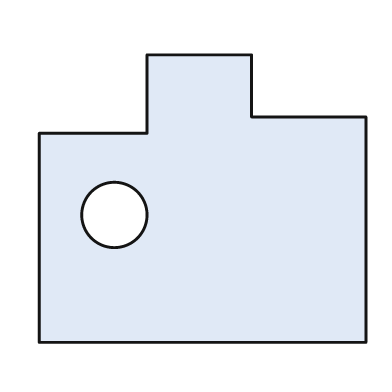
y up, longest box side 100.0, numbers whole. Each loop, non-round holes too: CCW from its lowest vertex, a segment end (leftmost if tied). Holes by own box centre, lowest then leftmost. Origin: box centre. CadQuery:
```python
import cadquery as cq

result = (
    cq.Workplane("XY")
    .moveTo(-50.0, -44.0)
    .lineTo(50.0, -44.0)
    .lineTo(50.0, 25.0)
    .lineTo(15.0, 25.0)
    .lineTo(15.0, 44.0)
    .lineTo(-17.0, 44.0)
    .lineTo(-17.0, 20.0)
    .lineTo(-50.0, 20.0)
    .close()
    .moveTo(-27.0, -5.0)
    .circle(10.0)
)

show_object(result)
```